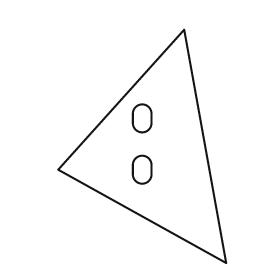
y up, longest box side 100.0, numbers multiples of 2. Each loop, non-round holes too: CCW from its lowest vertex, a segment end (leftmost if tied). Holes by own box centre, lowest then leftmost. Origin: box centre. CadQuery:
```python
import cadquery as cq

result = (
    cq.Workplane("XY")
    .moveTo(36.0, -50.0)
    .lineTo(18.0, 50.0)
    .lineTo(-36.0, -10.0)
    .close()
    .moveTo(-4.0, -12.0)
    .threePointArc((0.0, -16.0), (4.0, -12.0))
    .lineTo(4.0, -8.0)
    .threePointArc((0.0, -4.0), (-4.0, -8.0))
    .close()
    .moveTo(-4.0, 10.0)
    .threePointArc((0.0, 6.0), (4.0, 10.0))
    .lineTo(4.0, 14.0)
    .threePointArc((0.0, 18.0), (-4.0, 14.0))
    .close()
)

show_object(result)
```